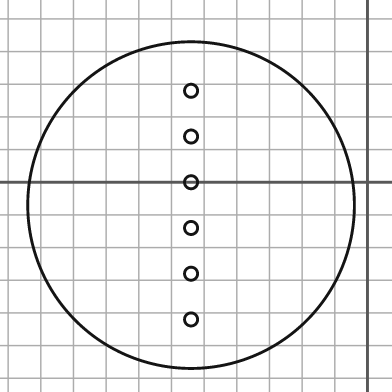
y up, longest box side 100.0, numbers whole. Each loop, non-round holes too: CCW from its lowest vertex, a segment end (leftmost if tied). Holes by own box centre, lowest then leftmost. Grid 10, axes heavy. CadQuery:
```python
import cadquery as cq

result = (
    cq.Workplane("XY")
    .moveTo(-54.0, -7.0)
    .circle(50.0)
    .moveTo(-54.0, -42.0)
    .circle(2.0)
    .moveTo(-54.0, -28.0)
    .circle(2.0)
    .moveTo(-54.0, -14.0)
    .circle(2.0)
    .moveTo(-54.0, 0.0)
    .circle(2.0)
    .moveTo(-54.0, 14.0)
    .circle(2.0)
    .moveTo(-54.0, 28.0)
    .circle(2.0)
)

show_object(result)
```